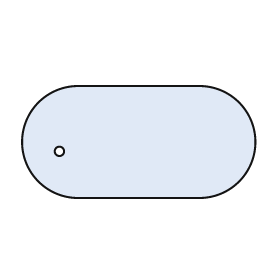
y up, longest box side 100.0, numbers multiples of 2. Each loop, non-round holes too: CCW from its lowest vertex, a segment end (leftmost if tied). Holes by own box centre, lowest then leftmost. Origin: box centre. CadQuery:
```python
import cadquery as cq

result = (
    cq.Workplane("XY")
    .moveTo(-26.0, -24.0)
    .lineTo(26.0, -24.0)
    .threePointArc((50.0, 0.0), (26.0, 24.0))
    .lineTo(-26.0, 24.0)
    .threePointArc((-50.0, 0.0), (-26.0, -24.0))
    .close()
    .moveTo(-34.0, -4.0)
    .circle(2.0)
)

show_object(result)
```